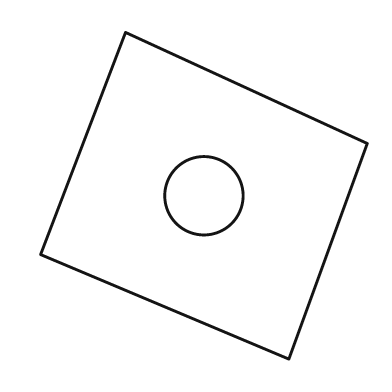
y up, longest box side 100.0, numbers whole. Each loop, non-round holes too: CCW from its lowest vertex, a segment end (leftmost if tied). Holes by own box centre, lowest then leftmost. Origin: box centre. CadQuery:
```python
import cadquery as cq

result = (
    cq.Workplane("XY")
    .moveTo(26.0, -50.0)
    .lineTo(50.0, 16.0)
    .lineTo(-24.0, 50.0)
    .lineTo(-50.0, -18.0)
    .close()
    .moveTo(0.0, 0.0)
    .circle(12.0)
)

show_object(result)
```